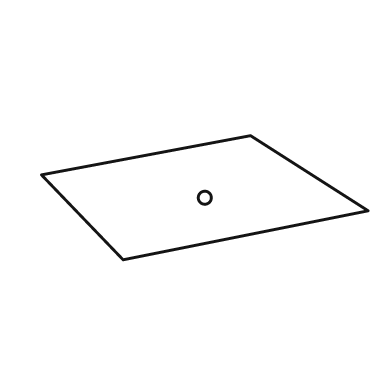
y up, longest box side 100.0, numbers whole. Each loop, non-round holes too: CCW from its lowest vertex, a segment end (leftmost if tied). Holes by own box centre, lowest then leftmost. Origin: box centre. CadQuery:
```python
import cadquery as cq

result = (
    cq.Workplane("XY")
    .moveTo(-25.0, -19.0)
    .lineTo(50.0, -4.0)
    .lineTo(14.0, 19.0)
    .lineTo(-50.0, 7.0)
    .close()
    .moveTo(0.0, 0.0)
    .circle(2.0)
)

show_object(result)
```